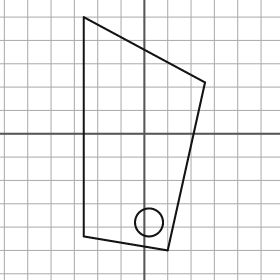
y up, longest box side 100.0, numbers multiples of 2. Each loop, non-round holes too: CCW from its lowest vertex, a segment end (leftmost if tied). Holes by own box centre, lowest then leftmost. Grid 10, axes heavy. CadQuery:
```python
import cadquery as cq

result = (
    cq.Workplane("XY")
    .moveTo(10.0, -50.0)
    .lineTo(26.0, 22.0)
    .lineTo(-26.0, 50.0)
    .lineTo(-26.0, -44.0)
    .close()
    .moveTo(2.0, -38.0)
    .circle(6.0)
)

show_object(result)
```